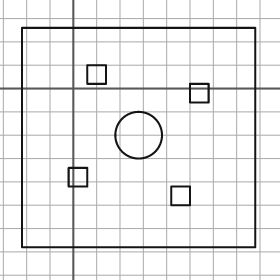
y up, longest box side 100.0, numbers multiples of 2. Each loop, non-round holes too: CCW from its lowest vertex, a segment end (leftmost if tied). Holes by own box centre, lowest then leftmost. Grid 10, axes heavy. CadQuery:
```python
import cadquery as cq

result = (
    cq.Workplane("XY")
    .moveTo(-22.0, -68.0)
    .lineTo(78.0, -68.0)
    .lineTo(78.0, 26.0)
    .lineTo(-22.0, 26.0)
    .close()
    .moveTo(42.0, -50.0)
    .lineTo(50.0, -50.0)
    .lineTo(50.0, -42.0)
    .lineTo(42.0, -42.0)
    .close()
    .moveTo(-2.0, -42.0)
    .lineTo(6.0, -42.0)
    .lineTo(6.0, -34.0)
    .lineTo(-2.0, -34.0)
    .close()
    .moveTo(28.0, -20.0)
    .circle(10.0)
    .moveTo(50.0, -6.0)
    .lineTo(58.0, -6.0)
    .lineTo(58.0, 2.0)
    .lineTo(50.0, 2.0)
    .close()
    .moveTo(6.0, 2.0)
    .lineTo(14.0, 2.0)
    .lineTo(14.0, 10.0)
    .lineTo(6.0, 10.0)
    .close()
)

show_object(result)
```